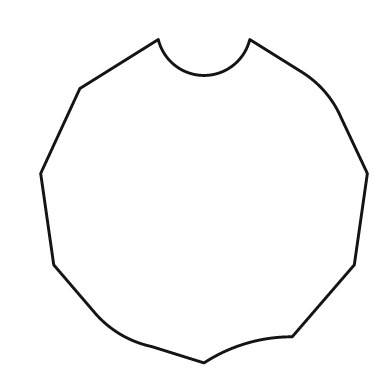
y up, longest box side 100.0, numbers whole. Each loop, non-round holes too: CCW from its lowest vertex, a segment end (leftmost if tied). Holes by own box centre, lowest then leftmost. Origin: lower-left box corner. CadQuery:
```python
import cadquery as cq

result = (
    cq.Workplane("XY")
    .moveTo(50.0, 0.0)
    .threePointArc((63.0, 6.0), (77.0, 8.0))
    .lineTo(96.0, 30.0)
    .lineTo(100.0, 58.0)
    .lineTo(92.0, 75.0)
    .threePointArc((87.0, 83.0), (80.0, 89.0))
    .lineTo(64.0, 99.0)
    .threePointArc((50.0, 88.0), (36.0, 99.0))
    .lineTo(12.0, 84.0)
    .lineTo(0.0, 58.0)
    .lineTo(4.0, 30.0)
    .lineTo(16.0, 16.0)
    .threePointArc((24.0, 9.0), (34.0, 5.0))
    .close()
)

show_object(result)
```